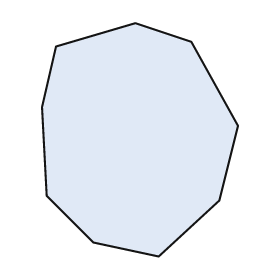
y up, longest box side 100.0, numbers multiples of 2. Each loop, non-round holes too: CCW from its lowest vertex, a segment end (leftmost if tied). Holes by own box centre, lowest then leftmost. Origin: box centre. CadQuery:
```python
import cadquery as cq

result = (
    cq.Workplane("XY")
    .moveTo(8.0, -50.0)
    .lineTo(34.0, -26.0)
    .lineTo(42.0, 6.0)
    .lineTo(22.0, 42.0)
    .lineTo(-2.0, 50.0)
    .lineTo(-36.0, 40.0)
    .lineTo(-42.0, 14.0)
    .lineTo(-40.0, -24.0)
    .lineTo(-20.0, -44.0)
    .close()
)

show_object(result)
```